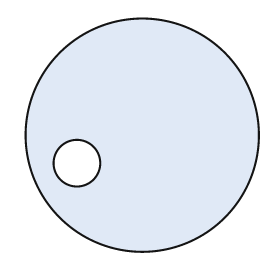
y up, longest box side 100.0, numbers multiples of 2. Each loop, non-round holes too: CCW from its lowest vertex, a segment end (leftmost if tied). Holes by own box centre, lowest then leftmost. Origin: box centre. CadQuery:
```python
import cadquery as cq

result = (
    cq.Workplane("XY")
    .moveTo(0.0, 0.0)
    .circle(50.0)
    .moveTo(-28.0, -12.0)
    .circle(10.0)
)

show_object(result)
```